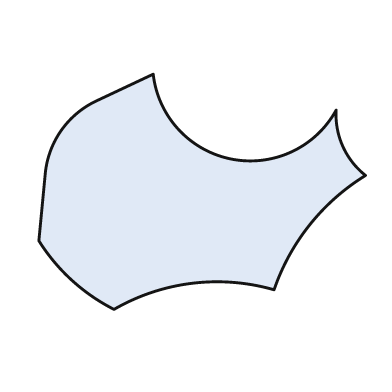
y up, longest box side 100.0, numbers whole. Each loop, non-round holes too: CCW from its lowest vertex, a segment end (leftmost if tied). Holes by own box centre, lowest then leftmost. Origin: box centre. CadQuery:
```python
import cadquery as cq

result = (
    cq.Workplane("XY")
    .moveTo(-27.0, -36.0)
    .threePointArc((-3.0, -28.0), (22.0, -30.0))
    .threePointArc((33.0, -10.0), (50.0, 5.0))
    .threePointArc((43.0, 14.0), (41.0, 25.0))
    .threePointArc((9.0, 10.0), (-15.0, 36.0))
    .lineTo(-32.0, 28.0)
    .threePointArc((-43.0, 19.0), (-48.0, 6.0))
    .lineTo(-50.0, -15.0)
    .threePointArc((-40.0, -27.0), (-27.0, -36.0))
    .close()
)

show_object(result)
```